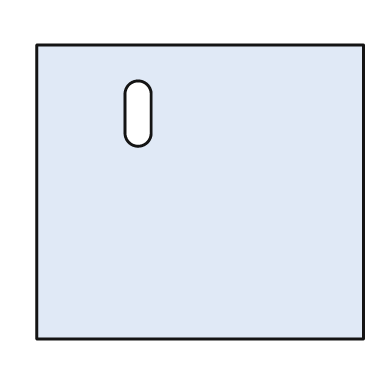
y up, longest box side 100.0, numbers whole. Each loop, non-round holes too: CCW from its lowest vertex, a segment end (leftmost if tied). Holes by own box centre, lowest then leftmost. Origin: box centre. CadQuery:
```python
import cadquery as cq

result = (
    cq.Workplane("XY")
    .moveTo(-50.0, -45.0)
    .lineTo(50.0, -45.0)
    .lineTo(50.0, 45.0)
    .lineTo(-50.0, 45.0)
    .close()
    .moveTo(-23.0, 18.0)
    .threePointArc((-19.0, 14.0), (-15.0, 18.0))
    .lineTo(-15.0, 30.0)
    .threePointArc((-19.0, 34.0), (-23.0, 30.0))
    .close()
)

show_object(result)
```